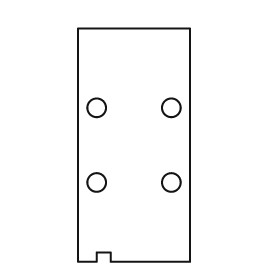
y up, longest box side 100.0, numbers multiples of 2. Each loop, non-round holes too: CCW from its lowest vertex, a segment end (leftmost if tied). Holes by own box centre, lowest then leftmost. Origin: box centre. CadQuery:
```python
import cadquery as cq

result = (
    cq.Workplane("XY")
    .moveTo(-24.0, -50.0)
    .lineTo(-16.0, -50.0)
    .lineTo(-16.0, -46.0)
    .lineTo(-10.0, -46.0)
    .lineTo(-10.0, -50.0)
    .lineTo(24.0, -50.0)
    .lineTo(24.0, 50.0)
    .lineTo(-24.0, 50.0)
    .close()
    .moveTo(-16.0, -16.0)
    .circle(4.0)
    .moveTo(16.0, -16.0)
    .circle(4.0)
    .moveTo(-16.0, 16.0)
    .circle(4.0)
    .moveTo(16.0, 16.0)
    .circle(4.0)
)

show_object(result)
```